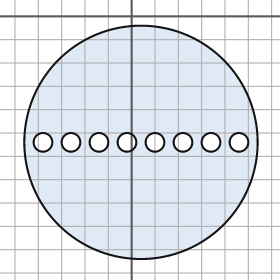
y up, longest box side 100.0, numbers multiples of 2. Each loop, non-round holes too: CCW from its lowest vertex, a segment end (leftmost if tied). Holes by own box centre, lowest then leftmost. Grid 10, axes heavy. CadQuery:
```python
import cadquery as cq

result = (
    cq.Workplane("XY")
    .moveTo(4.0, -54.0)
    .circle(50.0)
    .moveTo(-38.0, -54.0)
    .circle(4.0)
    .moveTo(-26.0, -54.0)
    .circle(4.0)
    .moveTo(-14.0, -54.0)
    .circle(4.0)
    .moveTo(-2.0, -54.0)
    .circle(4.0)
    .moveTo(10.0, -54.0)
    .circle(4.0)
    .moveTo(22.0, -54.0)
    .circle(4.0)
    .moveTo(34.0, -54.0)
    .circle(4.0)
    .moveTo(46.0, -54.0)
    .circle(4.0)
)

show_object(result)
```